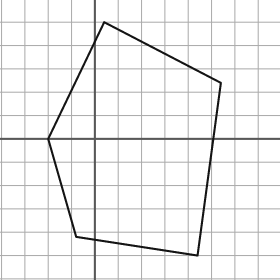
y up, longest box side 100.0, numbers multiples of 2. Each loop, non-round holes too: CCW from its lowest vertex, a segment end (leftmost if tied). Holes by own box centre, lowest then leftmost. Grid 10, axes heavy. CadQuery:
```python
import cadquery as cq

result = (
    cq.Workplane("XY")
    .moveTo(44.0, -50.0)
    .lineTo(54.0, 24.0)
    .lineTo(4.0, 50.0)
    .lineTo(-20.0, 0.0)
    .lineTo(-8.0, -42.0)
    .close()
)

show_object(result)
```